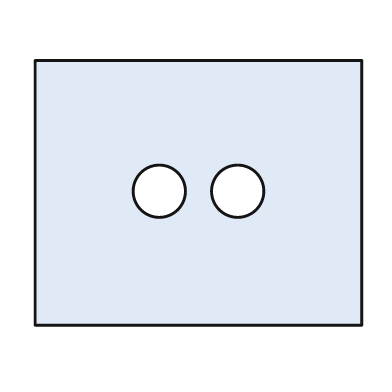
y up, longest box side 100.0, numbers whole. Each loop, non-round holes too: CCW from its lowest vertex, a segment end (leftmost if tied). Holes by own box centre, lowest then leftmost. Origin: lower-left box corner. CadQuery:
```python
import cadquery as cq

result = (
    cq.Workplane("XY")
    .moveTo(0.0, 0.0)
    .lineTo(100.0, 0.0)
    .lineTo(100.0, 81.0)
    .lineTo(0.0, 81.0)
    .close()
    .moveTo(38.0, 41.0)
    .circle(8.0)
    .moveTo(62.0, 41.0)
    .circle(8.0)
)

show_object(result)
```